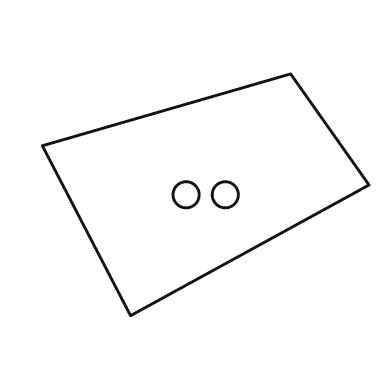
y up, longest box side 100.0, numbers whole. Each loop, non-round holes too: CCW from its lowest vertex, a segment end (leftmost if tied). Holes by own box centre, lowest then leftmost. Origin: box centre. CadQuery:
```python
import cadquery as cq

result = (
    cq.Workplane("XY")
    .moveTo(-23.0, -37.0)
    .lineTo(50.0, 3.0)
    .lineTo(26.0, 37.0)
    .lineTo(-50.0, 15.0)
    .close()
    .moveTo(-6.0, 0.0)
    .circle(4.0)
    .moveTo(6.0, 0.0)
    .circle(4.0)
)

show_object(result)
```